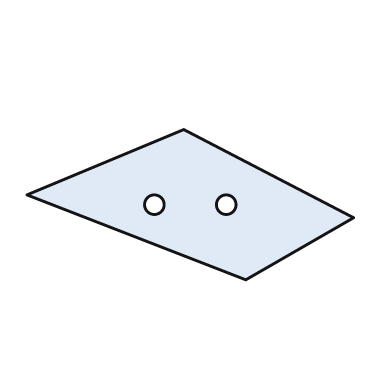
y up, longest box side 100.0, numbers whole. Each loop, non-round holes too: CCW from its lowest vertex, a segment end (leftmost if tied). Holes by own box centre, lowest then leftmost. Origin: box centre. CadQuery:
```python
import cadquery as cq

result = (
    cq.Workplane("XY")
    .moveTo(17.0, -23.0)
    .lineTo(50.0, -4.0)
    .lineTo(-2.0, 23.0)
    .lineTo(-50.0, 3.0)
    .close()
    .moveTo(-11.0, 0.0)
    .circle(3.0)
    .moveTo(11.0, 0.0)
    .circle(3.0)
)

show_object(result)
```